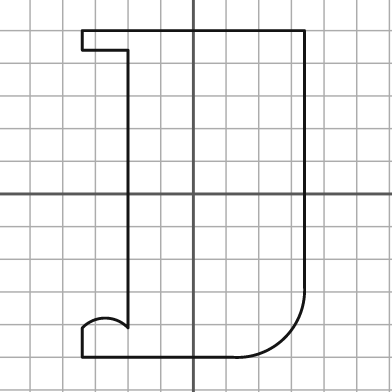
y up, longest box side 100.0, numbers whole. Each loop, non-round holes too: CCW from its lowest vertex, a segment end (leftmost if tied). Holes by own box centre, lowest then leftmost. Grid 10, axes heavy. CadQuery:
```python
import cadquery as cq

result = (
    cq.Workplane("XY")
    .moveTo(-34.0, -50.0)
    .lineTo(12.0, -50.0)
    .threePointArc((28.0, -44.0), (34.0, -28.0))
    .lineTo(34.0, 50.0)
    .lineTo(-34.0, 50.0)
    .lineTo(-34.0, 44.0)
    .lineTo(-20.0, 44.0)
    .lineTo(-20.0, -41.0)
    .threePointArc((-27.0, -38.0), (-34.0, -41.0))
    .close()
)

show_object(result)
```